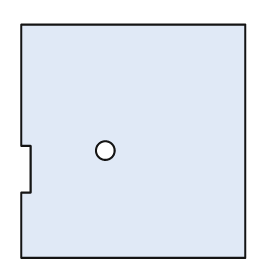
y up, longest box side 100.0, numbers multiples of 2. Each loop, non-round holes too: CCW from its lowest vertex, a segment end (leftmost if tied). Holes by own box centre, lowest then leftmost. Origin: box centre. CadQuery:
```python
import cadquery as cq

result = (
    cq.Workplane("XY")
    .moveTo(-48.0, -50.0)
    .lineTo(48.0, -50.0)
    .lineTo(48.0, 50.0)
    .lineTo(-48.0, 50.0)
    .lineTo(-48.0, -2.0)
    .lineTo(-44.0, -2.0)
    .lineTo(-44.0, -22.0)
    .lineTo(-48.0, -22.0)
    .close()
    .moveTo(-12.0, -4.0)
    .circle(4.0)
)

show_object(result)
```